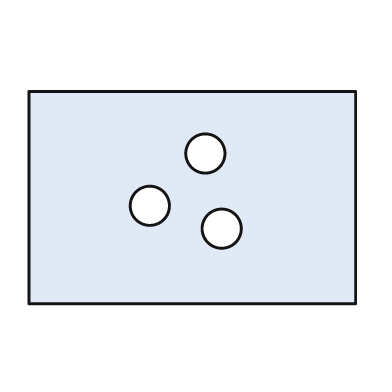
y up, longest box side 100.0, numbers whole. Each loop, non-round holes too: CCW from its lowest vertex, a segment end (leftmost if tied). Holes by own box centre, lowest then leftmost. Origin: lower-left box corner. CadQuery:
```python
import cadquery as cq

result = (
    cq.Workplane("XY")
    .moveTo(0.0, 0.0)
    .lineTo(100.0, 0.0)
    .lineTo(100.0, 65.0)
    .lineTo(0.0, 65.0)
    .close()
    .moveTo(59.0, 23.0)
    .circle(6.0)
    .moveTo(37.0, 30.0)
    .circle(6.0)
    .moveTo(54.0, 46.0)
    .circle(6.0)
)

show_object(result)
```